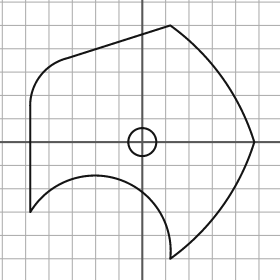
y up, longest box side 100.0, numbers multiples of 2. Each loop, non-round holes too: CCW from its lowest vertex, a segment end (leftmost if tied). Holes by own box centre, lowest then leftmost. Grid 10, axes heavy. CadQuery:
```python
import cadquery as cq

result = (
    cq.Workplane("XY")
    .moveTo(12.0, -50.0)
    .threePointArc((34.0, -28.0), (48.0, 0.0))
    .threePointArc((34.0, 28.0), (12.0, 50.0))
    .lineTo(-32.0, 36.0)
    .threePointArc((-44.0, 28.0), (-48.0, 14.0))
    .lineTo(-48.0, -30.0)
    .threePointArc((-10.0, -16.0), (12.0, -50.0))
    .close()
    .moveTo(0.0, 0.0)
    .circle(6.0)
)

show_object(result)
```